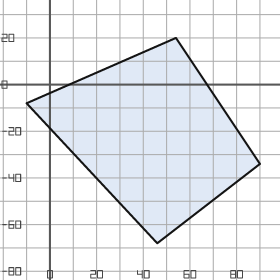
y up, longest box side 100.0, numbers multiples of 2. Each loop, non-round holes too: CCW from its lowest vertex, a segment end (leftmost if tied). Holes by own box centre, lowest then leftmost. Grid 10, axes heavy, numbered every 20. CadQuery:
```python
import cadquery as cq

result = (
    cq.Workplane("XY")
    .moveTo(46.0, -68.0)
    .lineTo(90.0, -34.0)
    .lineTo(54.0, 20.0)
    .lineTo(-10.0, -8.0)
    .close()
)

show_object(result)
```